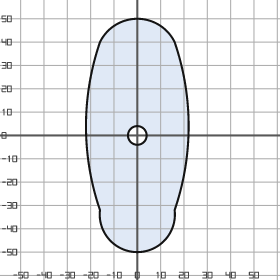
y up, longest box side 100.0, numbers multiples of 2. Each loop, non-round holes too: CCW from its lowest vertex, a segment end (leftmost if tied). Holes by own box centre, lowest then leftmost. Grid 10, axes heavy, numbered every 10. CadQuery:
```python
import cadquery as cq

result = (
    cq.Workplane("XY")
    .moveTo(-16.0, -32.0)
    .threePointArc((0.0, -50.0), (16.0, -32.0))
    .threePointArc((22.0, 4.0), (16.0, 40.0))
    .threePointArc((0.0, 50.0), (-16.0, 40.0))
    .threePointArc((-22.0, 4.0), (-16.0, -32.0))
    .close()
    .moveTo(0.0, 0.0)
    .circle(4.0)
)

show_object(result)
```